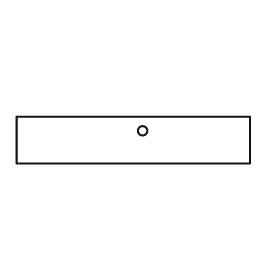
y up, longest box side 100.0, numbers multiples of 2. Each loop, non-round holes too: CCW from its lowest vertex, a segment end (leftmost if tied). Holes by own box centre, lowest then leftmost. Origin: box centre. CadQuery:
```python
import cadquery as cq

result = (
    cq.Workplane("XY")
    .moveTo(-50.0, -10.0)
    .lineTo(50.0, -10.0)
    .lineTo(50.0, 10.0)
    .lineTo(-50.0, 10.0)
    .close()
    .moveTo(4.0, 4.0)
    .circle(2.0)
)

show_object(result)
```